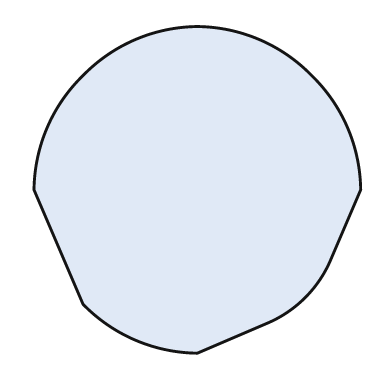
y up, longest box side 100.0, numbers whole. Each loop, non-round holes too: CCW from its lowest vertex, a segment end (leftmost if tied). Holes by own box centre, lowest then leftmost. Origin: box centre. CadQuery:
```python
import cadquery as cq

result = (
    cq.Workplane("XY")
    .moveTo(0.0, -50.0)
    .lineTo(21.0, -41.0)
    .threePointArc((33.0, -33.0), (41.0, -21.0))
    .lineTo(50.0, 0.0)
    .threePointArc((46.0, 19.0), (35.0, 35.0))
    .threePointArc((19.0, 46.0), (0.0, 50.0))
    .threePointArc((-19.0, 46.0), (-35.0, 35.0))
    .threePointArc((-46.0, 19.0), (-50.0, 0.0))
    .lineTo(-35.0, -35.0)
    .threePointArc((-19.0, -46.0), (0.0, -50.0))
    .close()
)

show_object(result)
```